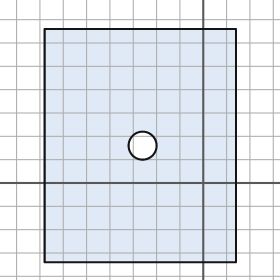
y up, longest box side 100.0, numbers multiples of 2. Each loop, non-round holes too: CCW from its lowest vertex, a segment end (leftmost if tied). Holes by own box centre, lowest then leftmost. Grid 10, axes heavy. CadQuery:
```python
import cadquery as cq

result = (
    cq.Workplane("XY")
    .moveTo(-68.0, -34.0)
    .lineTo(14.0, -34.0)
    .lineTo(14.0, 66.0)
    .lineTo(-68.0, 66.0)
    .close()
    .moveTo(-26.0, 16.0)
    .circle(6.0)
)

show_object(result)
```